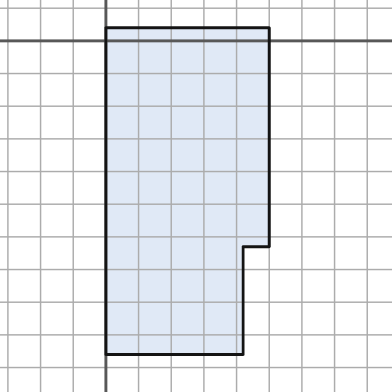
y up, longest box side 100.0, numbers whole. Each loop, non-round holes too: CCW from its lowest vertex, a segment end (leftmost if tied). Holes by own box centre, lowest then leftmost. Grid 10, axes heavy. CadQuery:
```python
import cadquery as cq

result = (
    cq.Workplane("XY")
    .moveTo(0.0, -96.0)
    .lineTo(42.0, -96.0)
    .lineTo(42.0, -63.0)
    .lineTo(50.0, -63.0)
    .lineTo(50.0, 4.0)
    .lineTo(0.0, 4.0)
    .close()
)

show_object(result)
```